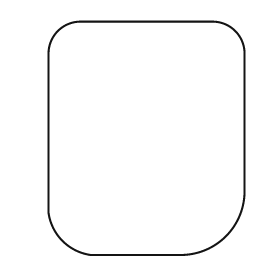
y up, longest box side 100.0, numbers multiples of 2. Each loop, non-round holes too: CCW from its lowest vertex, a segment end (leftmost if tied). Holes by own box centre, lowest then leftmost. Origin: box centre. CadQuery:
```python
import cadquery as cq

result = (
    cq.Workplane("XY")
    .moveTo(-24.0, -50.0)
    .lineTo(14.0, -50.0)
    .threePointArc((34.0, -42.0), (42.0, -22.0))
    .lineTo(42.0, 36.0)
    .threePointArc((38.0, 46.0), (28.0, 50.0))
    .lineTo(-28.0, 50.0)
    .threePointArc((-38.0, 46.0), (-42.0, 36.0))
    .lineTo(-42.0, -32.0)
    .threePointArc((-36.0, -44.0), (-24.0, -50.0))
    .close()
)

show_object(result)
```